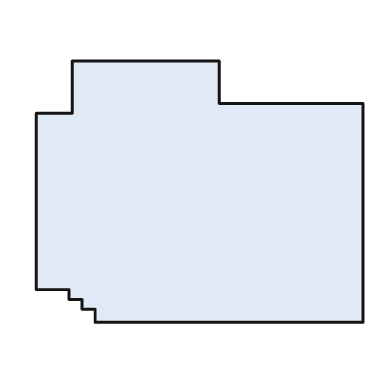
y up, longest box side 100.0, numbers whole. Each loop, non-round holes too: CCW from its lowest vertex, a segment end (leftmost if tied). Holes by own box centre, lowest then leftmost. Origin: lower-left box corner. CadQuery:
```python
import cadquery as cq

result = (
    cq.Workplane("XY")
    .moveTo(18.0, 0.0)
    .lineTo(100.0, 0.0)
    .lineTo(100.0, 67.0)
    .lineTo(56.0, 67.0)
    .lineTo(56.0, 80.0)
    .lineTo(11.0, 80.0)
    .lineTo(11.0, 64.0)
    .lineTo(0.0, 64.0)
    .lineTo(0.0, 10.0)
    .lineTo(10.0, 10.0)
    .lineTo(10.0, 7.0)
    .lineTo(14.0, 7.0)
    .lineTo(14.0, 4.0)
    .lineTo(18.0, 4.0)
    .close()
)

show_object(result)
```